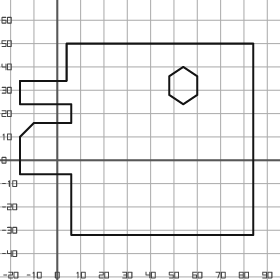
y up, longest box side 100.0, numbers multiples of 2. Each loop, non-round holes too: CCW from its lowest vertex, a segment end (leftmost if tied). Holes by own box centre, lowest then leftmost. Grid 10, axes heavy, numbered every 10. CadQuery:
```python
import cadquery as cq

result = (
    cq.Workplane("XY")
    .moveTo(6.0, -32.0)
    .lineTo(84.0, -32.0)
    .lineTo(84.0, 50.0)
    .lineTo(4.0, 50.0)
    .lineTo(4.0, 34.0)
    .lineTo(-16.0, 34.0)
    .lineTo(-16.0, 24.0)
    .lineTo(6.0, 24.0)
    .lineTo(6.0, 16.0)
    .lineTo(-10.0, 16.0)
    .lineTo(-16.0, 10.0)
    .lineTo(-16.0, -6.0)
    .lineTo(6.0, -6.0)
    .close()
    .moveTo(54.0, 24.0)
    .lineTo(60.0, 28.0)
    .lineTo(60.0, 36.0)
    .lineTo(54.0, 40.0)
    .lineTo(48.0, 36.0)
    .lineTo(48.0, 28.0)
    .close()
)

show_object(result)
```